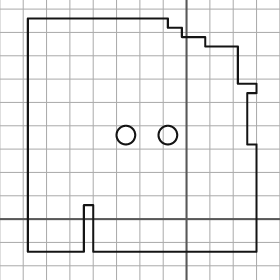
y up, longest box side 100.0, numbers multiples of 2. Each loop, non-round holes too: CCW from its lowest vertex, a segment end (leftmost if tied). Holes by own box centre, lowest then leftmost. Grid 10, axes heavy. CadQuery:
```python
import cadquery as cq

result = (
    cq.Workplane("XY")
    .moveTo(-68.0, -14.0)
    .lineTo(-44.0, -14.0)
    .lineTo(-44.0, 6.0)
    .lineTo(-40.0, 6.0)
    .lineTo(-40.0, -14.0)
    .lineTo(30.0, -14.0)
    .lineTo(30.0, 32.0)
    .lineTo(26.0, 32.0)
    .lineTo(26.0, 54.0)
    .lineTo(30.0, 54.0)
    .lineTo(30.0, 58.0)
    .lineTo(22.0, 58.0)
    .lineTo(22.0, 74.0)
    .lineTo(8.0, 74.0)
    .lineTo(8.0, 78.0)
    .lineTo(-2.0, 78.0)
    .lineTo(-2.0, 82.0)
    .lineTo(-8.0, 82.0)
    .lineTo(-8.0, 86.0)
    .lineTo(-68.0, 86.0)
    .close()
    .moveTo(-26.0, 36.0)
    .circle(4.0)
    .moveTo(-8.0, 36.0)
    .circle(4.0)
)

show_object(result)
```